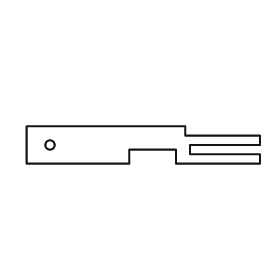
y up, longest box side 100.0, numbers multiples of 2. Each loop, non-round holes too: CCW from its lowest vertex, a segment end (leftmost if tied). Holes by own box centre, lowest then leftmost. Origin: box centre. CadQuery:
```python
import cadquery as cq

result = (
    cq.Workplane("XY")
    .moveTo(-50.0, -8.0)
    .lineTo(-6.0, -8.0)
    .lineTo(-6.0, -2.0)
    .lineTo(14.0, -2.0)
    .lineTo(14.0, -8.0)
    .lineTo(50.0, -8.0)
    .lineTo(50.0, -4.0)
    .lineTo(20.0, -4.0)
    .lineTo(20.0, 0.0)
    .lineTo(50.0, 0.0)
    .lineTo(50.0, 4.0)
    .lineTo(18.0, 4.0)
    .lineTo(18.0, 8.0)
    .lineTo(-50.0, 8.0)
    .close()
    .moveTo(-40.0, 0.0)
    .circle(2.0)
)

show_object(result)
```